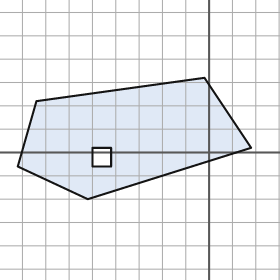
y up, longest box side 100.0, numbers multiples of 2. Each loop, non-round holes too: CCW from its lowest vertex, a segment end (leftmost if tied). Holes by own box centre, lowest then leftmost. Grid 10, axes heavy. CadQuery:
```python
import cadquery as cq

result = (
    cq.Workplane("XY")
    .moveTo(-52.0, -20.0)
    .lineTo(18.0, 2.0)
    .lineTo(-2.0, 32.0)
    .lineTo(-74.0, 22.0)
    .lineTo(-82.0, -6.0)
    .close()
    .moveTo(-50.0, -6.0)
    .lineTo(-42.0, -6.0)
    .lineTo(-42.0, 2.0)
    .lineTo(-50.0, 2.0)
    .close()
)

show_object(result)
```